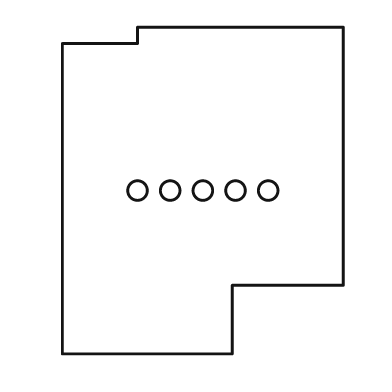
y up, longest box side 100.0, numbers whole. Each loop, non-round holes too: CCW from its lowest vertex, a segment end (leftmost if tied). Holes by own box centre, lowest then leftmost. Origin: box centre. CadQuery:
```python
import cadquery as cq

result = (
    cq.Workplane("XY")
    .moveTo(-43.0, -50.0)
    .lineTo(9.0, -50.0)
    .lineTo(9.0, -29.0)
    .lineTo(43.0, -29.0)
    .lineTo(43.0, 50.0)
    .lineTo(-20.0, 50.0)
    .lineTo(-20.0, 45.0)
    .lineTo(-43.0, 45.0)
    .close()
    .moveTo(-20.0, 0.0)
    .circle(3.0)
    .moveTo(-10.0, 0.0)
    .circle(3.0)
    .moveTo(0.0, 0.0)
    .circle(3.0)
    .moveTo(10.0, 0.0)
    .circle(3.0)
    .moveTo(20.0, 0.0)
    .circle(3.0)
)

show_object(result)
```